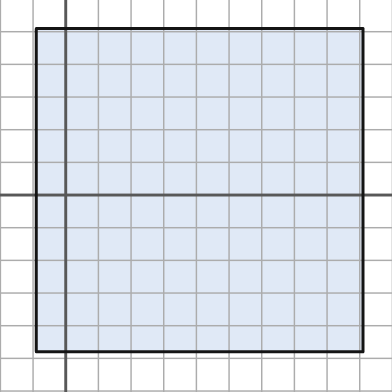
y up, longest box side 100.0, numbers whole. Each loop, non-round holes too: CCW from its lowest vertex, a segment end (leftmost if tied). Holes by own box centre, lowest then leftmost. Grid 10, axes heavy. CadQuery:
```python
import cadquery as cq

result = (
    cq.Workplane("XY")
    .moveTo(-9.0, -48.0)
    .lineTo(91.0, -48.0)
    .lineTo(91.0, 51.0)
    .lineTo(-9.0, 51.0)
    .close()
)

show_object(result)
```